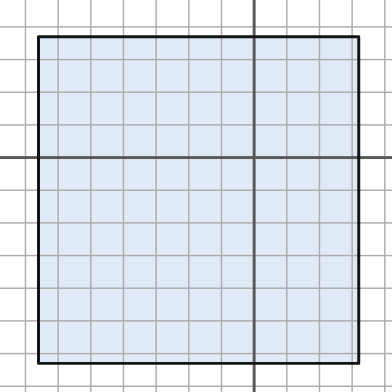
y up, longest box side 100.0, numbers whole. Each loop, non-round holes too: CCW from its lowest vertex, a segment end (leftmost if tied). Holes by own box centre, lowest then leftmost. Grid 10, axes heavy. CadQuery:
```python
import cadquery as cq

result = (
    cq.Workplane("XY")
    .moveTo(-66.0, -63.0)
    .lineTo(32.0, -63.0)
    .lineTo(32.0, 37.0)
    .lineTo(-66.0, 37.0)
    .close()
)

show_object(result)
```